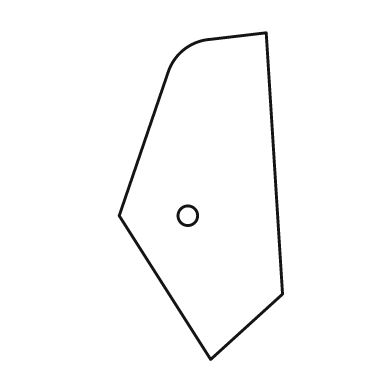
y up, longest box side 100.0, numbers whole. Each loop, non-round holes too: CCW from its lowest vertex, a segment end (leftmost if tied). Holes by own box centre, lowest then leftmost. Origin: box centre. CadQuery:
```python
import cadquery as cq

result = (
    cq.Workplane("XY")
    .moveTo(3.0, -50.0)
    .lineTo(25.0, -30.0)
    .lineTo(20.0, 50.0)
    .lineTo(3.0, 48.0)
    .threePointArc((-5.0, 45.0), (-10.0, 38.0))
    .lineTo(-25.0, -6.0)
    .close()
    .moveTo(-4.0, -6.0)
    .circle(3.0)
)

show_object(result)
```